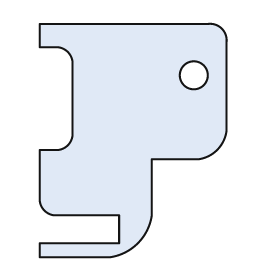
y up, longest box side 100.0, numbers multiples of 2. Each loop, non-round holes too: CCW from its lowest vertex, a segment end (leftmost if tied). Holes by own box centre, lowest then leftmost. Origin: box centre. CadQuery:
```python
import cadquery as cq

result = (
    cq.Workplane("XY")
    .moveTo(-40.0, -50.0)
    .lineTo(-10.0, -50.0)
    .threePointArc((2.0, -44.0), (8.0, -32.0))
    .lineTo(8.0, -8.0)
    .lineTo(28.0, -8.0)
    .threePointArc((36.0, -4.0), (40.0, 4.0))
    .lineTo(40.0, 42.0)
    .threePointArc((38.0, 48.0), (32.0, 50.0))
    .lineTo(-40.0, 50.0)
    .lineTo(-40.0, 40.0)
    .lineTo(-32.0, 40.0)
    .threePointArc((-28.0, 38.0), (-26.0, 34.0))
    .lineTo(-26.0, 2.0)
    .threePointArc((-28.0, -2.0), (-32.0, -4.0))
    .lineTo(-40.0, -4.0)
    .lineTo(-40.0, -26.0)
    .threePointArc((-38.0, -30.0), (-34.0, -32.0))
    .lineTo(-6.0, -32.0)
    .lineTo(-6.0, -44.0)
    .lineTo(-40.0, -44.0)
    .close()
    .moveTo(26.0, 28.0)
    .circle(6.0)
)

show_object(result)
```